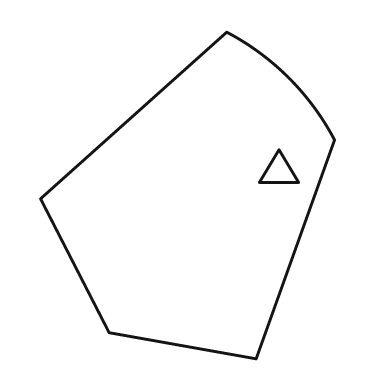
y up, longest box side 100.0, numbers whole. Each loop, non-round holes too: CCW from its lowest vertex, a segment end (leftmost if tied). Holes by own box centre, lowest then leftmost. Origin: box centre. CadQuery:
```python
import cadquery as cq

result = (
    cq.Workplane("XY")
    .moveTo(21.0, -50.0)
    .lineTo(45.0, 17.0)
    .threePointArc((31.0, 36.0), (12.0, 50.0))
    .lineTo(-45.0, -1.0)
    .lineTo(-24.0, -42.0)
    .close()
    .moveTo(22.0, 4.0)
    .lineTo(34.0, 4.0)
    .lineTo(28.0, 14.0)
    .close()
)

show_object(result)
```